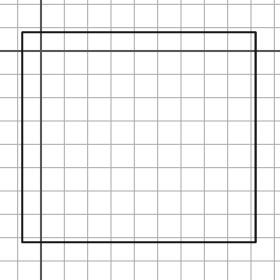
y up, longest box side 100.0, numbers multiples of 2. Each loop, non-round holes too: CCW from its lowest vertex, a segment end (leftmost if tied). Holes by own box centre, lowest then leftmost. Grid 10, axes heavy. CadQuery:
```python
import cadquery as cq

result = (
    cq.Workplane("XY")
    .moveTo(-8.0, -82.0)
    .lineTo(92.0, -82.0)
    .lineTo(92.0, 8.0)
    .lineTo(-8.0, 8.0)
    .close()
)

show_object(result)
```